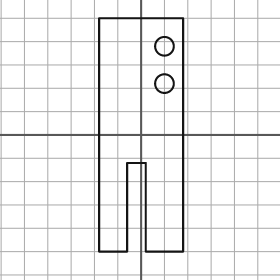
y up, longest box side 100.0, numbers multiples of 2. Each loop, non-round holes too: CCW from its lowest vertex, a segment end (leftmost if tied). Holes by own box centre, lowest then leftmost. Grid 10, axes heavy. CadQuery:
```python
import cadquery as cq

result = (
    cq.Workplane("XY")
    .moveTo(-18.0, -50.0)
    .lineTo(-6.0, -50.0)
    .lineTo(-6.0, -12.0)
    .lineTo(2.0, -12.0)
    .lineTo(2.0, -50.0)
    .lineTo(18.0, -50.0)
    .lineTo(18.0, 50.0)
    .lineTo(-18.0, 50.0)
    .close()
    .moveTo(10.0, 22.0)
    .circle(4.0)
    .moveTo(10.0, 38.0)
    .circle(4.0)
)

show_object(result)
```